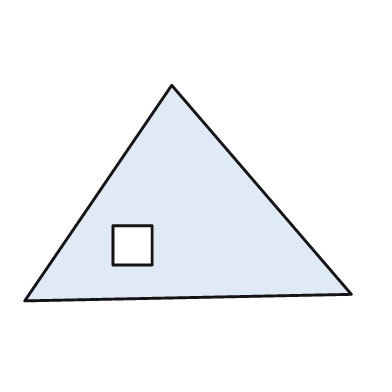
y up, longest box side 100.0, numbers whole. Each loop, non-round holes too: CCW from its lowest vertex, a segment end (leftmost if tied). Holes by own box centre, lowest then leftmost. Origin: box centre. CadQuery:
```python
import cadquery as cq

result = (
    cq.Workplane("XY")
    .moveTo(-50.0, -33.0)
    .lineTo(50.0, -31.0)
    .lineTo(-5.0, 33.0)
    .close()
    .moveTo(-23.0, -22.0)
    .lineTo(-11.0, -22.0)
    .lineTo(-11.0, -10.0)
    .lineTo(-23.0, -10.0)
    .close()
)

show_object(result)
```